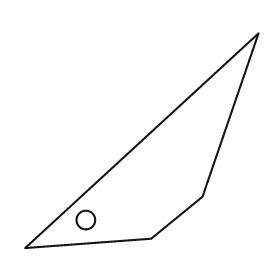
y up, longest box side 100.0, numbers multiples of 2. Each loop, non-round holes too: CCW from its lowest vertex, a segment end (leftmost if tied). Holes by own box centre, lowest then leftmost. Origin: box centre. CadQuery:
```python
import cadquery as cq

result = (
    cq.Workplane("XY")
    .moveTo(-50.0, -46.0)
    .lineTo(4.0, -42.0)
    .lineTo(26.0, -24.0)
    .lineTo(50.0, 46.0)
    .close()
    .moveTo(-24.0, -34.0)
    .circle(4.0)
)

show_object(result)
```